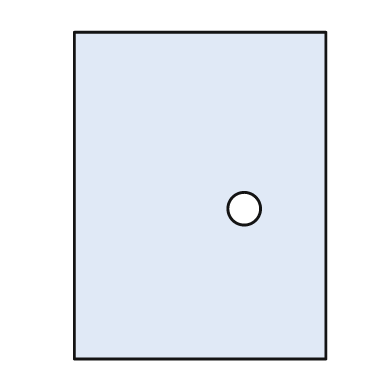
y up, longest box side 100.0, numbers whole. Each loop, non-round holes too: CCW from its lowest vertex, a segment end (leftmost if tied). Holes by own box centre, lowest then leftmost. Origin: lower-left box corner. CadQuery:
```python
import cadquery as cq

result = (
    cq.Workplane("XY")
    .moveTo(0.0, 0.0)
    .lineTo(77.0, 0.0)
    .lineTo(77.0, 100.0)
    .lineTo(0.0, 100.0)
    .close()
    .moveTo(52.0, 46.0)
    .circle(5.0)
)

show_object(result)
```